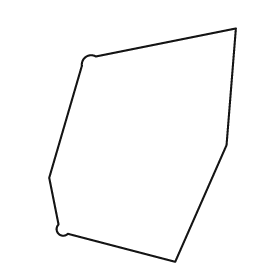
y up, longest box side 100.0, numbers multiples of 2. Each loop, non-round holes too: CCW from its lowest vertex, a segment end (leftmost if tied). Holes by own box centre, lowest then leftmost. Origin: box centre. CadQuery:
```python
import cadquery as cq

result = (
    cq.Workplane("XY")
    .moveTo(14.0, -50.0)
    .lineTo(36.0, 0.0)
    .lineTo(40.0, 50.0)
    .lineTo(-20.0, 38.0)
    .threePointArc((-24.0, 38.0), (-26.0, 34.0))
    .lineTo(-40.0, -14.0)
    .lineTo(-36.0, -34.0)
    .threePointArc((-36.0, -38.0), (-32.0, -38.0))
    .close()
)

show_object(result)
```